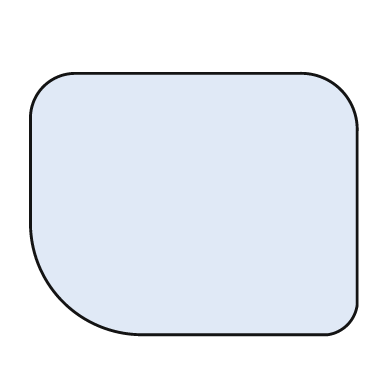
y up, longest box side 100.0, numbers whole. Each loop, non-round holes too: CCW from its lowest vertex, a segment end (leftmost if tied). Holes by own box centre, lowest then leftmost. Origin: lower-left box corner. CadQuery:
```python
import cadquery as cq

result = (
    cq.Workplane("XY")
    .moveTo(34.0, 0.0)
    .lineTo(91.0, 0.0)
    .threePointArc((97.0, 3.0), (100.0, 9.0))
    .lineTo(100.0, 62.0)
    .threePointArc((95.0, 75.0), (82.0, 80.0))
    .lineTo(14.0, 80.0)
    .threePointArc((4.0, 76.0), (0.0, 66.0))
    .lineTo(0.0, 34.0)
    .threePointArc((10.0, 10.0), (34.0, 0.0))
    .close()
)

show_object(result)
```